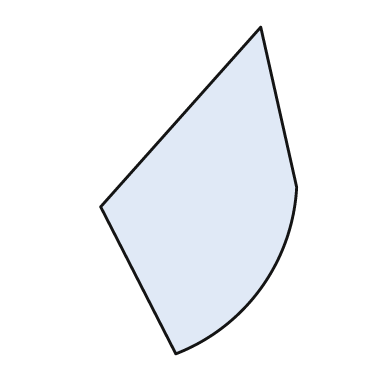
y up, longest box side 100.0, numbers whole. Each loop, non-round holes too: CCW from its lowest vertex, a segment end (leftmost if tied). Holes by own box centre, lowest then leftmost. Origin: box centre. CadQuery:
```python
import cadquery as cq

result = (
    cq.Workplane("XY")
    .moveTo(-7.0, -50.0)
    .threePointArc((19.0, -30.0), (30.0, 1.0))
    .lineTo(19.0, 50.0)
    .lineTo(-30.0, -5.0)
    .close()
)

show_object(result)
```